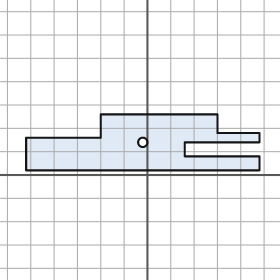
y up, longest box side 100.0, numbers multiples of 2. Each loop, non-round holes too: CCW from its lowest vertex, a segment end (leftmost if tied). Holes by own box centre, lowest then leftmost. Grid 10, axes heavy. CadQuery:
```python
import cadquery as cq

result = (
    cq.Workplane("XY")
    .moveTo(-52.0, 2.0)
    .lineTo(48.0, 2.0)
    .lineTo(48.0, 8.0)
    .lineTo(16.0, 8.0)
    .lineTo(16.0, 14.0)
    .lineTo(48.0, 14.0)
    .lineTo(48.0, 18.0)
    .lineTo(30.0, 18.0)
    .lineTo(30.0, 26.0)
    .lineTo(-20.0, 26.0)
    .lineTo(-20.0, 16.0)
    .lineTo(-52.0, 16.0)
    .close()
    .moveTo(-2.0, 14.0)
    .circle(2.0)
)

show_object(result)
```